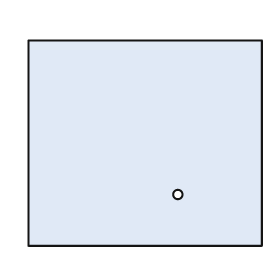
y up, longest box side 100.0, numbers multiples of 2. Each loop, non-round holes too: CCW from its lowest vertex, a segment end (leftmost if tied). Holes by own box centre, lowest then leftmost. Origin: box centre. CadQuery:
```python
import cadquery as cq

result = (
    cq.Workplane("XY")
    .moveTo(-50.0, -44.0)
    .lineTo(50.0, -44.0)
    .lineTo(50.0, 44.0)
    .lineTo(-50.0, 44.0)
    .close()
    .moveTo(14.0, -22.0)
    .circle(2.0)
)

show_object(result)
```